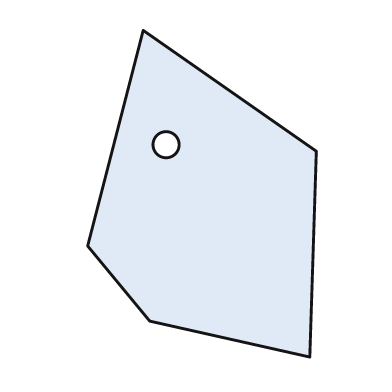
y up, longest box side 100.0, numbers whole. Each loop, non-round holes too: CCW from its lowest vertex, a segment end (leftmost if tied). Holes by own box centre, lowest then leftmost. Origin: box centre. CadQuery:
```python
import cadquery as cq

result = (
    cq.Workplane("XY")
    .moveTo(33.0, -50.0)
    .lineTo(35.0, 13.0)
    .lineTo(-18.0, 50.0)
    .lineTo(-35.0, -16.0)
    .lineTo(-16.0, -39.0)
    .close()
    .moveTo(-11.0, 15.0)
    .circle(4.0)
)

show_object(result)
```